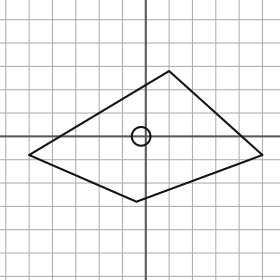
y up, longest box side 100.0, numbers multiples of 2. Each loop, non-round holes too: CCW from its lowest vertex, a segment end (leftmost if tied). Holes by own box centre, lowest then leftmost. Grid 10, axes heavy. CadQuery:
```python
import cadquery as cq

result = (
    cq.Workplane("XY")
    .moveTo(-4.0, -28.0)
    .lineTo(50.0, -8.0)
    .lineTo(10.0, 28.0)
    .lineTo(-50.0, -8.0)
    .close()
    .moveTo(-2.0, 0.0)
    .circle(4.0)
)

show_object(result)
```